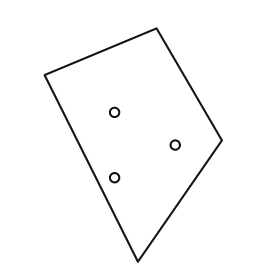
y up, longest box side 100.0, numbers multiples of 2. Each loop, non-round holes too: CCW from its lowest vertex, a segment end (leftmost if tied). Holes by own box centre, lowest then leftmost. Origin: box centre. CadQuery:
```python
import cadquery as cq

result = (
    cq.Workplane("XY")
    .moveTo(2.0, -50.0)
    .lineTo(38.0, 2.0)
    .lineTo(10.0, 50.0)
    .lineTo(-38.0, 30.0)
    .close()
    .moveTo(-8.0, -14.0)
    .circle(2.0)
    .moveTo(18.0, 0.0)
    .circle(2.0)
    .moveTo(-8.0, 14.0)
    .circle(2.0)
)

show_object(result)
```